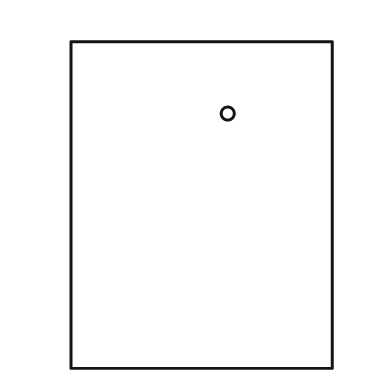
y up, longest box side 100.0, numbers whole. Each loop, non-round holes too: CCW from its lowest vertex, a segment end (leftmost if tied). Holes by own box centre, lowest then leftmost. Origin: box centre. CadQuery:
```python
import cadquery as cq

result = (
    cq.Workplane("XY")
    .moveTo(-40.0, -50.0)
    .lineTo(40.0, -50.0)
    .lineTo(40.0, 50.0)
    .lineTo(-40.0, 50.0)
    .close()
    .moveTo(8.0, 28.0)
    .circle(2.0)
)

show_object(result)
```